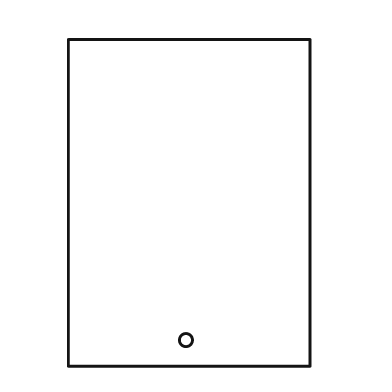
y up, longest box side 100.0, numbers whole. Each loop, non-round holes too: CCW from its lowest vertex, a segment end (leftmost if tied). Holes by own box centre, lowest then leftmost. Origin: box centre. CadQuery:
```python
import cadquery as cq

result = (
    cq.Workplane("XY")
    .moveTo(-37.0, -50.0)
    .lineTo(37.0, -50.0)
    .lineTo(37.0, 50.0)
    .lineTo(-37.0, 50.0)
    .close()
    .moveTo(-1.0, -42.0)
    .circle(2.0)
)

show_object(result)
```